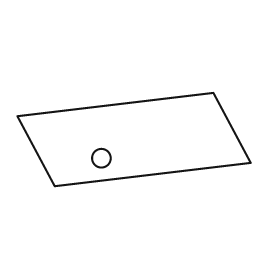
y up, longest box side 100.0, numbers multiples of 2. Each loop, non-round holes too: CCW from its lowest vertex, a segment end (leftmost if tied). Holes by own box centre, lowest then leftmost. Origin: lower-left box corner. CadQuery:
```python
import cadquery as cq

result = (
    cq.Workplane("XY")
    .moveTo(16.0, 0.0)
    .lineTo(100.0, 10.0)
    .lineTo(84.0, 40.0)
    .lineTo(0.0, 30.0)
    .close()
    .moveTo(36.0, 12.0)
    .circle(4.0)
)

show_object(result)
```